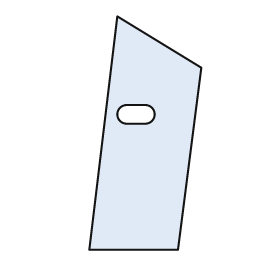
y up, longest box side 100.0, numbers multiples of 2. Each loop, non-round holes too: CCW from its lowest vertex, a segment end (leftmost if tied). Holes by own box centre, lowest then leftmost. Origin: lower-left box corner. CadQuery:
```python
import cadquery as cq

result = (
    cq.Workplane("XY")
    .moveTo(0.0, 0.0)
    .lineTo(38.0, 0.0)
    .lineTo(48.0, 78.0)
    .lineTo(12.0, 100.0)
    .close()
    .moveTo(16.0, 54.0)
    .lineTo(24.0, 54.0)
    .threePointArc((28.0, 58.0), (24.0, 62.0))
    .lineTo(16.0, 62.0)
    .threePointArc((12.0, 58.0), (16.0, 54.0))
    .close()
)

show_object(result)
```